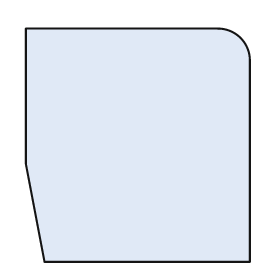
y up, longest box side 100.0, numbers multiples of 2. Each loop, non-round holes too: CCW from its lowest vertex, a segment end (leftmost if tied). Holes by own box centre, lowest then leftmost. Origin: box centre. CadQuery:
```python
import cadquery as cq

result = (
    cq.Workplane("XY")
    .moveTo(-40.0, -50.0)
    .lineTo(48.0, -50.0)
    .lineTo(48.0, 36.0)
    .threePointArc((44.0, 46.0), (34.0, 50.0))
    .lineTo(-48.0, 50.0)
    .lineTo(-48.0, -8.0)
    .close()
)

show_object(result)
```